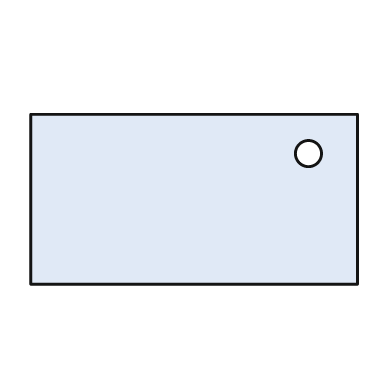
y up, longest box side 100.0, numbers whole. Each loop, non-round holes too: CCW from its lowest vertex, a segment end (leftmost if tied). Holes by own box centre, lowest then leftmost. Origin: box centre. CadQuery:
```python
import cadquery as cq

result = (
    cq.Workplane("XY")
    .moveTo(-50.0, -26.0)
    .lineTo(50.0, -26.0)
    .lineTo(50.0, 26.0)
    .lineTo(-50.0, 26.0)
    .close()
    .moveTo(35.0, 14.0)
    .circle(4.0)
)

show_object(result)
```